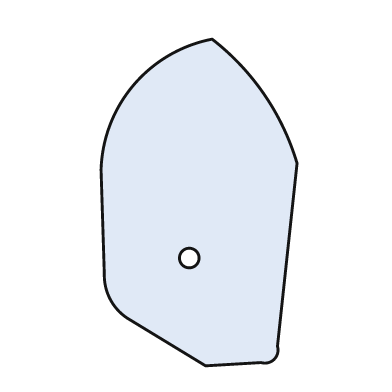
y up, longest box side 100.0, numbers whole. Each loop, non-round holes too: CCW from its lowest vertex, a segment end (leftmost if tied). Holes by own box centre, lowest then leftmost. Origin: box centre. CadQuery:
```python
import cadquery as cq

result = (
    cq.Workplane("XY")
    .moveTo(2.0, -50.0)
    .lineTo(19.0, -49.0)
    .threePointArc((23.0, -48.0), (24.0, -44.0))
    .lineTo(30.0, 12.0)
    .threePointArc((20.0, 33.0), (4.0, 50.0))
    .threePointArc((-20.0, 36.0), (-30.0, 10.0))
    .lineTo(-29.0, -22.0)
    .threePointArc((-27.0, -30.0), (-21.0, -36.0))
    .close()
    .moveTo(-3.0, -17.0)
    .circle(3.0)
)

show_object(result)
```